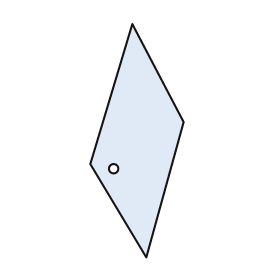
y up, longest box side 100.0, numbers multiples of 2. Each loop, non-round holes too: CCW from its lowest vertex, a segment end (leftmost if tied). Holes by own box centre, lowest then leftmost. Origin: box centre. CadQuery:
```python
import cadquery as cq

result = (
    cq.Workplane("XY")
    .moveTo(4.0, -50.0)
    .lineTo(20.0, 8.0)
    .lineTo(-2.0, 50.0)
    .lineTo(-20.0, -10.0)
    .close()
    .moveTo(-10.0, -12.0)
    .circle(2.0)
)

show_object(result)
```